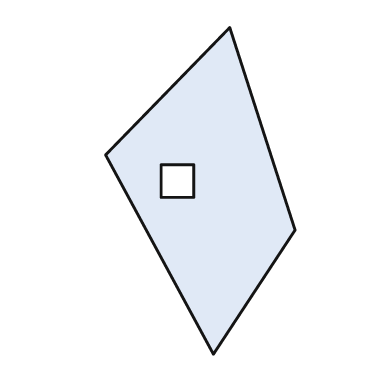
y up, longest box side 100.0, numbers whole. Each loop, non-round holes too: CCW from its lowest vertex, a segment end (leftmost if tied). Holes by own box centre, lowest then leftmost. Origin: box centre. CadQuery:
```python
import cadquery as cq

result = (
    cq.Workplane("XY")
    .moveTo(4.0, -50.0)
    .lineTo(29.0, -12.0)
    .lineTo(9.0, 50.0)
    .lineTo(-29.0, 11.0)
    .close()
    .moveTo(-12.0, -2.0)
    .lineTo(-2.0, -2.0)
    .lineTo(-2.0, 8.0)
    .lineTo(-12.0, 8.0)
    .close()
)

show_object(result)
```